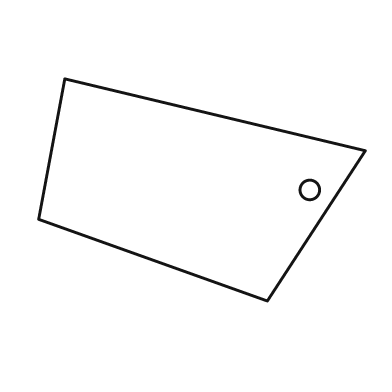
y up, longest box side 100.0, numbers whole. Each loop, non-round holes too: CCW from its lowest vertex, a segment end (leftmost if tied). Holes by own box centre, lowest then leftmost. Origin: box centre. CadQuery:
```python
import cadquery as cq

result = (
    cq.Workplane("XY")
    .moveTo(20.0, -34.0)
    .lineTo(50.0, 12.0)
    .lineTo(-42.0, 34.0)
    .lineTo(-50.0, -9.0)
    .close()
    .moveTo(33.0, 0.0)
    .circle(3.0)
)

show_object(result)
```